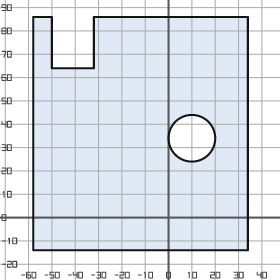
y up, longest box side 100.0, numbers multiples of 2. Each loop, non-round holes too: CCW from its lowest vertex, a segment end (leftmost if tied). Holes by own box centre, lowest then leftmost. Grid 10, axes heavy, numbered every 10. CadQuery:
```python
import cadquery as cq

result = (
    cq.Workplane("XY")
    .moveTo(-58.0, -14.0)
    .lineTo(34.0, -14.0)
    .lineTo(34.0, 86.0)
    .lineTo(-32.0, 86.0)
    .lineTo(-32.0, 64.0)
    .lineTo(-50.0, 64.0)
    .lineTo(-50.0, 86.0)
    .lineTo(-58.0, 86.0)
    .close()
    .moveTo(10.0, 34.0)
    .circle(10.0)
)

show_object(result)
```